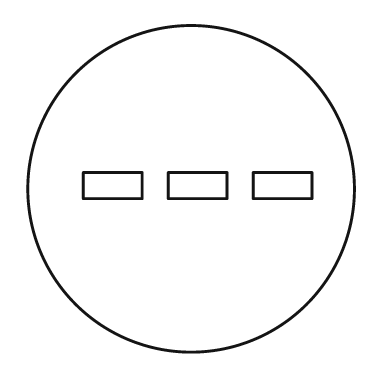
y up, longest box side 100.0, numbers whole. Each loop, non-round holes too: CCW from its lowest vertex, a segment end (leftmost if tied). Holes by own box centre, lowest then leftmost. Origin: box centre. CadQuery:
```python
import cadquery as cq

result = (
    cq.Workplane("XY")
    .moveTo(0.0, 0.0)
    .circle(50.0)
    .moveTo(-33.0, -3.0)
    .lineTo(-15.0, -3.0)
    .lineTo(-15.0, 5.0)
    .lineTo(-33.0, 5.0)
    .close()
    .moveTo(-7.0, -3.0)
    .lineTo(11.0, -3.0)
    .lineTo(11.0, 5.0)
    .lineTo(-7.0, 5.0)
    .close()
    .moveTo(19.0, -3.0)
    .lineTo(37.0, -3.0)
    .lineTo(37.0, 5.0)
    .lineTo(19.0, 5.0)
    .close()
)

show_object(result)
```